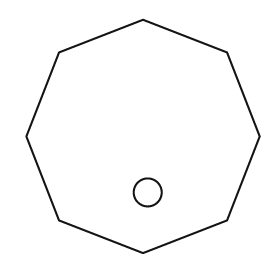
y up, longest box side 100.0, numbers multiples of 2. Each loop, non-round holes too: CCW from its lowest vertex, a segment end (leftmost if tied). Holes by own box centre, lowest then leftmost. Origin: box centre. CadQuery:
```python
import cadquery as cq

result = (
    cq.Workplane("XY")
    .moveTo(0.0, -50.0)
    .lineTo(36.0, -36.0)
    .lineTo(50.0, 0.0)
    .lineTo(36.0, 36.0)
    .lineTo(0.0, 50.0)
    .lineTo(-36.0, 36.0)
    .lineTo(-50.0, 0.0)
    .lineTo(-36.0, -36.0)
    .close()
    .moveTo(2.0, -24.0)
    .circle(6.0)
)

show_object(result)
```